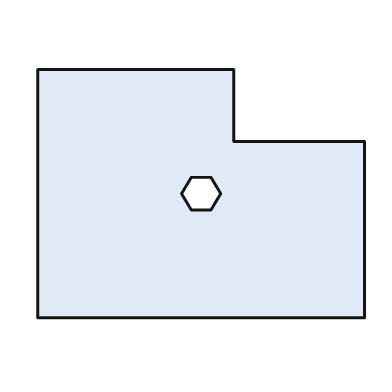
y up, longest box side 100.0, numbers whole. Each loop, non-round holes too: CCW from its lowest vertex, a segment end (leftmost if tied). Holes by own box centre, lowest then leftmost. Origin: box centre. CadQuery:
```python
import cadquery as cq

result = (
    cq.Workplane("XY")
    .moveTo(-50.0, -38.0)
    .lineTo(50.0, -38.0)
    .lineTo(50.0, 16.0)
    .lineTo(10.0, 16.0)
    .lineTo(10.0, 38.0)
    .lineTo(-50.0, 38.0)
    .close()
    .moveTo(-3.0, -5.0)
    .lineTo(3.0, -5.0)
    .lineTo(6.0, 0.0)
    .lineTo(3.0, 5.0)
    .lineTo(-3.0, 5.0)
    .lineTo(-6.0, 0.0)
    .close()
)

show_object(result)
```